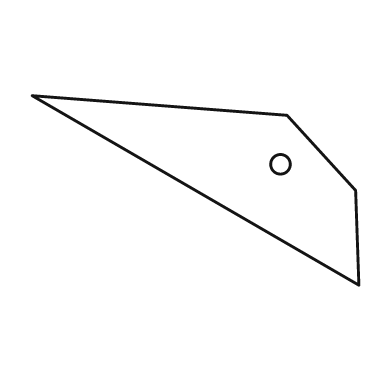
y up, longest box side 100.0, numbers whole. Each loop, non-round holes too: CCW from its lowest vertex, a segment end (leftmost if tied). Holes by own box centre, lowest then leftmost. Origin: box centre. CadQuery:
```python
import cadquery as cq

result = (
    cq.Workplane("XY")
    .moveTo(50.0, -29.0)
    .lineTo(49.0, 0.0)
    .lineTo(28.0, 23.0)
    .lineTo(-50.0, 29.0)
    .close()
    .moveTo(26.0, 8.0)
    .circle(3.0)
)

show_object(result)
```